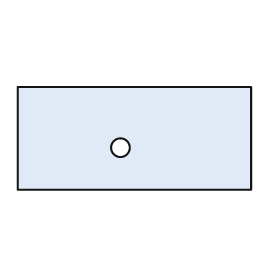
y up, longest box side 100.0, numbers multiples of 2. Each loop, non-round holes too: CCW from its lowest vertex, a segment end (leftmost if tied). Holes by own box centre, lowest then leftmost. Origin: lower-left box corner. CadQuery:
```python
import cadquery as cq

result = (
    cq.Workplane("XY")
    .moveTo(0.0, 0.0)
    .lineTo(100.0, 0.0)
    .lineTo(100.0, 44.0)
    .lineTo(0.0, 44.0)
    .close()
    .moveTo(44.0, 18.0)
    .circle(4.0)
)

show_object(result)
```